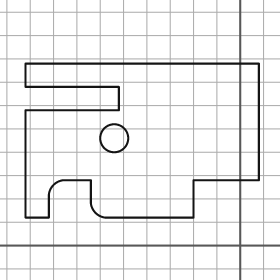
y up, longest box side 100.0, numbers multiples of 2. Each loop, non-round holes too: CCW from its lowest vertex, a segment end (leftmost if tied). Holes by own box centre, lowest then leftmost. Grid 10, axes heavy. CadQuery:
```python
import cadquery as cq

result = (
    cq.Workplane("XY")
    .moveTo(-92.0, 12.0)
    .lineTo(-82.0, 12.0)
    .lineTo(-82.0, 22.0)
    .threePointArc((-80.0, 26.0), (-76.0, 28.0))
    .lineTo(-64.0, 28.0)
    .lineTo(-64.0, 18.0)
    .threePointArc((-62.0, 14.0), (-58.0, 12.0))
    .lineTo(-20.0, 12.0)
    .lineTo(-20.0, 28.0)
    .lineTo(8.0, 28.0)
    .lineTo(8.0, 78.0)
    .lineTo(-92.0, 78.0)
    .lineTo(-92.0, 68.0)
    .lineTo(-52.0, 68.0)
    .lineTo(-52.0, 58.0)
    .lineTo(-92.0, 58.0)
    .close()
    .moveTo(-54.0, 46.0)
    .circle(6.0)
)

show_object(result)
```